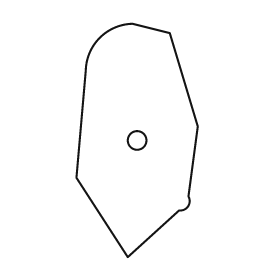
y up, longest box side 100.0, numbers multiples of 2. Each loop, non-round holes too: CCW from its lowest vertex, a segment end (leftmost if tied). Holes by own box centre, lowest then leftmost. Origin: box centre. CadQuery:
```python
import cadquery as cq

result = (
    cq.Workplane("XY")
    .moveTo(-4.0, -50.0)
    .lineTo(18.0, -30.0)
    .threePointArc((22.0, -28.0), (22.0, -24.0))
    .lineTo(26.0, 6.0)
    .lineTo(14.0, 46.0)
    .lineTo(-2.0, 50.0)
    .threePointArc((-16.0, 44.0), (-22.0, 30.0))
    .lineTo(-26.0, -16.0)
    .close()
    .moveTo(0.0, 0.0)
    .circle(4.0)
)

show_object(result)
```